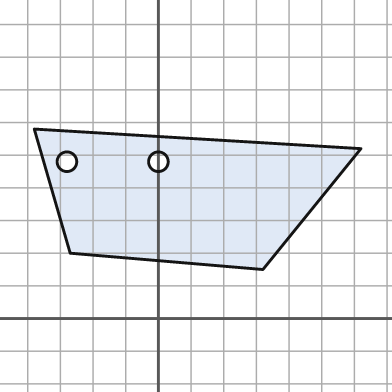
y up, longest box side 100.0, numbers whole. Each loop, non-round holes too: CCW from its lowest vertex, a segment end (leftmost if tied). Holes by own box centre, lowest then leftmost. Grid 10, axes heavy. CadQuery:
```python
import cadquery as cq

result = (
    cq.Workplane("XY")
    .moveTo(32.0, 15.0)
    .lineTo(62.0, 52.0)
    .lineTo(-38.0, 58.0)
    .lineTo(-27.0, 20.0)
    .close()
    .moveTo(-28.0, 48.0)
    .circle(3.0)
    .moveTo(0.0, 48.0)
    .circle(3.0)
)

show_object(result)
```